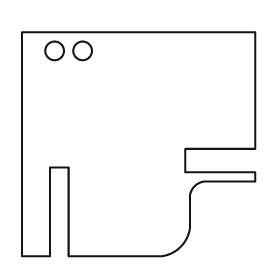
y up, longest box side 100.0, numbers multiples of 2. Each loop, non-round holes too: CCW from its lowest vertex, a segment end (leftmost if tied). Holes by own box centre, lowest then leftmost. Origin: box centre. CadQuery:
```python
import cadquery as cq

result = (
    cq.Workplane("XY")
    .moveTo(-50.0, -48.0)
    .lineTo(-38.0, -48.0)
    .lineTo(-38.0, -10.0)
    .lineTo(-30.0, -10.0)
    .lineTo(-30.0, -48.0)
    .lineTo(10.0, -48.0)
    .threePointArc((18.0, -44.0), (22.0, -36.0))
    .lineTo(22.0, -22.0)
    .threePointArc((24.0, -18.0), (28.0, -16.0))
    .lineTo(50.0, -16.0)
    .lineTo(50.0, -12.0)
    .lineTo(20.0, -12.0)
    .lineTo(20.0, -2.0)
    .lineTo(50.0, -2.0)
    .lineTo(50.0, 48.0)
    .lineTo(-50.0, 48.0)
    .close()
    .moveTo(-36.0, 40.0)
    .circle(4.0)
    .moveTo(-24.0, 40.0)
    .circle(4.0)
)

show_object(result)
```